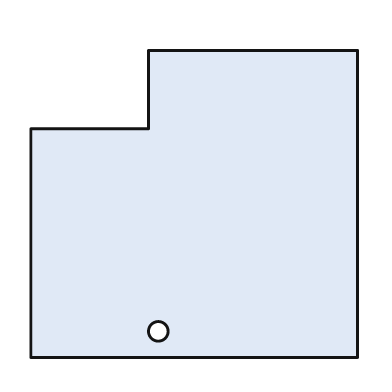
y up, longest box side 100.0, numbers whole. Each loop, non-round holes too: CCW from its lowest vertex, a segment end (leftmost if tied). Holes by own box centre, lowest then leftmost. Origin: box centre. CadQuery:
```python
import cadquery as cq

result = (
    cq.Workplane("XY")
    .moveTo(-50.0, -47.0)
    .lineTo(50.0, -47.0)
    .lineTo(50.0, 47.0)
    .lineTo(-14.0, 47.0)
    .lineTo(-14.0, 23.0)
    .lineTo(-50.0, 23.0)
    .close()
    .moveTo(-11.0, -39.0)
    .circle(3.0)
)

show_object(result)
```